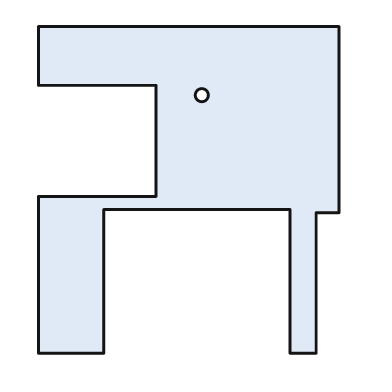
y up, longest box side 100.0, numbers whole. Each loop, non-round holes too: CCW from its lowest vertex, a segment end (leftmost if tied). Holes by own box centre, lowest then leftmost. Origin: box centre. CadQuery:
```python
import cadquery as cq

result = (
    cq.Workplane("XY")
    .moveTo(-46.0, -50.0)
    .lineTo(-26.0, -50.0)
    .lineTo(-26.0, -6.0)
    .lineTo(31.0, -6.0)
    .lineTo(31.0, -50.0)
    .lineTo(39.0, -50.0)
    .lineTo(39.0, -7.0)
    .lineTo(46.0, -7.0)
    .lineTo(46.0, 50.0)
    .lineTo(-46.0, 50.0)
    .lineTo(-46.0, 32.0)
    .lineTo(-10.0, 32.0)
    .lineTo(-10.0, -2.0)
    .lineTo(-46.0, -2.0)
    .close()
    .moveTo(4.0, 29.0)
    .circle(2.0)
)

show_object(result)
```